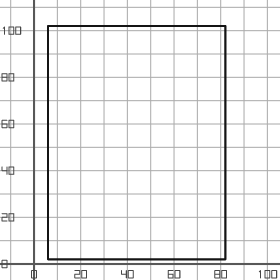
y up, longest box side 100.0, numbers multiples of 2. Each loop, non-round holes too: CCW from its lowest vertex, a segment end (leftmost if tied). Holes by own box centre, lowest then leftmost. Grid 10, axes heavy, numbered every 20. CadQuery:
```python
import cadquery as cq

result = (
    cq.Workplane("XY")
    .moveTo(6.0, 2.0)
    .lineTo(82.0, 2.0)
    .lineTo(82.0, 102.0)
    .lineTo(6.0, 102.0)
    .close()
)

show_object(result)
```